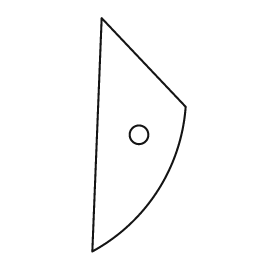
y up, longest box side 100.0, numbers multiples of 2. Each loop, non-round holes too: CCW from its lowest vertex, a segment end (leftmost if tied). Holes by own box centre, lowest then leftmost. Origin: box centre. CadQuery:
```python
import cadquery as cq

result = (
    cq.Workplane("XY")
    .moveTo(-20.0, -50.0)
    .threePointArc((8.0, -24.0), (20.0, 12.0))
    .lineTo(-16.0, 50.0)
    .close()
    .moveTo(0.0, 0.0)
    .circle(4.0)
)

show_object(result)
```